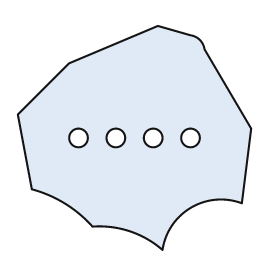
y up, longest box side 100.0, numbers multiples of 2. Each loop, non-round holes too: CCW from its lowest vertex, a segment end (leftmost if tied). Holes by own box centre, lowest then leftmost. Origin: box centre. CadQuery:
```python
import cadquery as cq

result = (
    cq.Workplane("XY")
    .moveTo(12.0, -48.0)
    .threePointArc((24.0, -30.0), (46.0, -28.0))
    .lineTo(50.0, 4.0)
    .lineTo(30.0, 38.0)
    .threePointArc((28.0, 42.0), (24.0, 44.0))
    .lineTo(10.0, 48.0)
    .lineTo(-28.0, 32.0)
    .lineTo(-50.0, 10.0)
    .lineTo(-44.0, -22.0)
    .threePointArc((-30.0, -28.0), (-18.0, -38.0))
    .threePointArc((-2.0, -40.0), (12.0, -48.0))
    .close()
    .moveTo(-24.0, 0.0)
    .circle(4.0)
    .moveTo(-8.0, 0.0)
    .circle(4.0)
    .moveTo(8.0, 0.0)
    .circle(4.0)
    .moveTo(24.0, 0.0)
    .circle(4.0)
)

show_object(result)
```